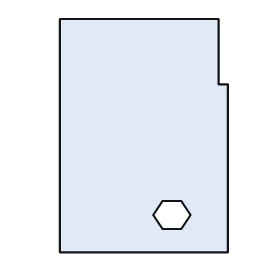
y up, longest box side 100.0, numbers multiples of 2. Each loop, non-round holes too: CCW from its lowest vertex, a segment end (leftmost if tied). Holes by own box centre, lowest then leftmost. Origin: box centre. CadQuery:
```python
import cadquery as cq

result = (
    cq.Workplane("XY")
    .moveTo(-36.0, -50.0)
    .lineTo(36.0, -50.0)
    .lineTo(36.0, 22.0)
    .lineTo(32.0, 22.0)
    .lineTo(32.0, 50.0)
    .lineTo(-36.0, 50.0)
    .close()
    .moveTo(8.0, -40.0)
    .lineTo(16.0, -40.0)
    .lineTo(20.0, -34.0)
    .lineTo(16.0, -28.0)
    .lineTo(8.0, -28.0)
    .lineTo(4.0, -34.0)
    .close()
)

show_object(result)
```